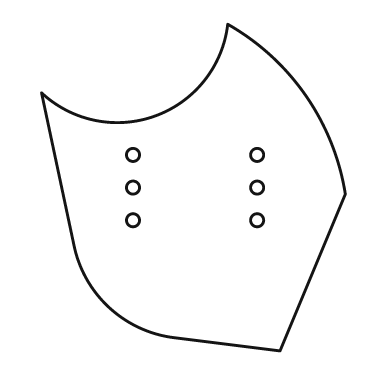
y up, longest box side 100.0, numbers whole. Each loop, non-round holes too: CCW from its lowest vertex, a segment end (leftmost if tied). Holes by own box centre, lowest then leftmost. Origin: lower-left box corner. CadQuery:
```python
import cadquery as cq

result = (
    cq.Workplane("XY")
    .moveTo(73.0, 0.0)
    .lineTo(93.0, 48.0)
    .threePointArc((81.0, 78.0), (57.0, 100.0))
    .threePointArc((35.0, 72.0), (0.0, 79.0))
    .lineTo(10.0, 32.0)
    .threePointArc((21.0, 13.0), (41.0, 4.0))
    .close()
    .moveTo(28.0, 40.0)
    .circle(2.0)
    .moveTo(66.0, 40.0)
    .circle(2.0)
    .moveTo(28.0, 50.0)
    .circle(2.0)
    .moveTo(66.0, 50.0)
    .circle(2.0)
    .moveTo(28.0, 60.0)
    .circle(2.0)
    .moveTo(66.0, 60.0)
    .circle(2.0)
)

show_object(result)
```